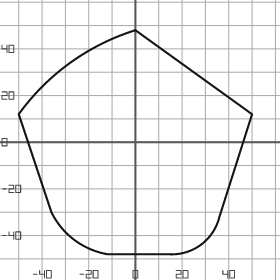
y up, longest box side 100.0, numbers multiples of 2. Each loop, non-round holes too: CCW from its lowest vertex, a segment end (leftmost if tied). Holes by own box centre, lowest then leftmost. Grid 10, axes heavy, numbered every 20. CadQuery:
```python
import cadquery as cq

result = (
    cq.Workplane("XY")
    .moveTo(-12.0, -48.0)
    .lineTo(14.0, -48.0)
    .threePointArc((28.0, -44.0), (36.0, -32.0))
    .lineTo(50.0, 12.0)
    .lineTo(0.0, 48.0)
    .threePointArc((-28.0, 34.0), (-50.0, 12.0))
    .lineTo(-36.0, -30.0)
    .threePointArc((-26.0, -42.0), (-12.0, -48.0))
    .close()
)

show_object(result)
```